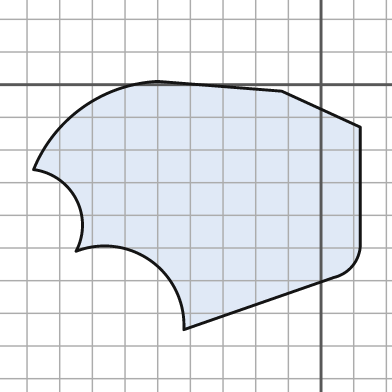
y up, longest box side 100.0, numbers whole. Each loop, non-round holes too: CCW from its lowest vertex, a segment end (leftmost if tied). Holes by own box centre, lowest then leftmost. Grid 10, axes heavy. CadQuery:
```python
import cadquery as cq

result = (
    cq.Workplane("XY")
    .moveTo(-42.0, -75.0)
    .lineTo(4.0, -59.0)
    .threePointArc((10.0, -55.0), (12.0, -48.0))
    .lineTo(12.0, -13.0)
    .lineTo(-12.0, -2.0)
    .lineTo(-50.0, 1.0)
    .threePointArc((-73.0, -7.0), (-88.0, -26.0))
    .threePointArc((-75.0, -35.0), (-75.0, -51.0))
    .threePointArc((-52.0, -54.0), (-42.0, -75.0))
    .close()
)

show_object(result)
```